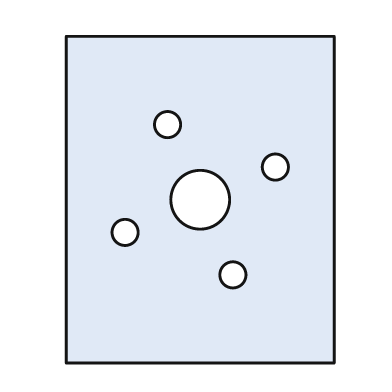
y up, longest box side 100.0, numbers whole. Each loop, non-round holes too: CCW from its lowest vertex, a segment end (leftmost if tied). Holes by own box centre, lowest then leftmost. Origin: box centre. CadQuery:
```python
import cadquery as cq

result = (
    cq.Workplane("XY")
    .moveTo(-41.0, -50.0)
    .lineTo(41.0, -50.0)
    .lineTo(41.0, 50.0)
    .lineTo(-41.0, 50.0)
    .close()
    .moveTo(10.0, -23.0)
    .circle(4.0)
    .moveTo(-23.0, -10.0)
    .circle(4.0)
    .moveTo(0.0, 0.0)
    .circle(9.0)
    .moveTo(23.0, 10.0)
    .circle(4.0)
    .moveTo(-10.0, 23.0)
    .circle(4.0)
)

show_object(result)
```